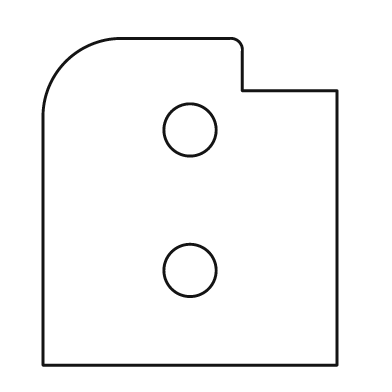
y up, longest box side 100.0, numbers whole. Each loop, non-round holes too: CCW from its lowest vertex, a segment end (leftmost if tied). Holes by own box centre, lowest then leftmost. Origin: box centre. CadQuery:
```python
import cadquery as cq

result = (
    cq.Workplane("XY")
    .moveTo(-45.0, -50.0)
    .lineTo(45.0, -50.0)
    .lineTo(45.0, 34.0)
    .lineTo(16.0, 34.0)
    .lineTo(16.0, 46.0)
    .threePointArc((15.0, 49.0), (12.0, 50.0))
    .lineTo(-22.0, 50.0)
    .threePointArc((-38.0, 43.0), (-45.0, 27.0))
    .close()
    .moveTo(0.0, -21.0)
    .circle(8.0)
    .moveTo(0.0, 22.0)
    .circle(8.0)
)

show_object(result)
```